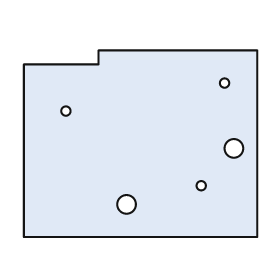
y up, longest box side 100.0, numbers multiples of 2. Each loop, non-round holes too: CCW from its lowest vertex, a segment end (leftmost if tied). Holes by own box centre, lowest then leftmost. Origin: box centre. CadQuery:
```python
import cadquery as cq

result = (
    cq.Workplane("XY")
    .moveTo(-50.0, -40.0)
    .lineTo(50.0, -40.0)
    .lineTo(50.0, 40.0)
    .lineTo(-18.0, 40.0)
    .lineTo(-18.0, 34.0)
    .lineTo(-50.0, 34.0)
    .close()
    .moveTo(-6.0, -26.0)
    .circle(4.0)
    .moveTo(26.0, -18.0)
    .circle(2.0)
    .moveTo(40.0, -2.0)
    .circle(4.0)
    .moveTo(-32.0, 14.0)
    .circle(2.0)
    .moveTo(36.0, 26.0)
    .circle(2.0)
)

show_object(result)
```